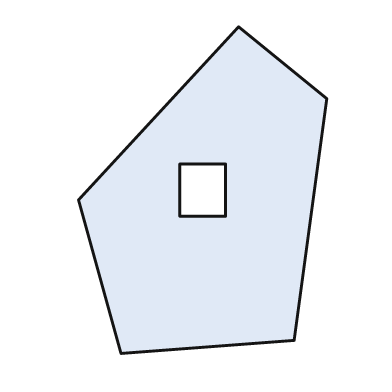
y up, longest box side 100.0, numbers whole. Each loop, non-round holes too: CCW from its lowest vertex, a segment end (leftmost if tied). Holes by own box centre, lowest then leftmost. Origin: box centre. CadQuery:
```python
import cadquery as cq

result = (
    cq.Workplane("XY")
    .moveTo(-25.0, -50.0)
    .lineTo(28.0, -46.0)
    .lineTo(38.0, 28.0)
    .lineTo(11.0, 50.0)
    .lineTo(-38.0, -3.0)
    .close()
    .moveTo(-7.0, -8.0)
    .lineTo(7.0, -8.0)
    .lineTo(7.0, 8.0)
    .lineTo(-7.0, 8.0)
    .close()
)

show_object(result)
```